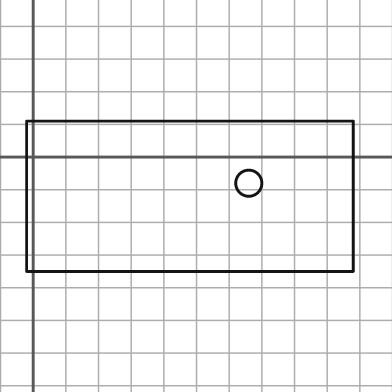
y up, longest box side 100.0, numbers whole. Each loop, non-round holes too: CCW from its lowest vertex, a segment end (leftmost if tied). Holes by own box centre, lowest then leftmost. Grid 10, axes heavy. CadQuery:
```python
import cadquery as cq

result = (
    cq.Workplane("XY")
    .moveTo(-2.0, -35.0)
    .lineTo(98.0, -35.0)
    .lineTo(98.0, 11.0)
    .lineTo(-2.0, 11.0)
    .close()
    .moveTo(66.0, -8.0)
    .circle(4.0)
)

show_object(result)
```